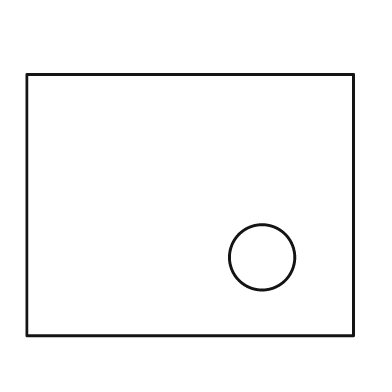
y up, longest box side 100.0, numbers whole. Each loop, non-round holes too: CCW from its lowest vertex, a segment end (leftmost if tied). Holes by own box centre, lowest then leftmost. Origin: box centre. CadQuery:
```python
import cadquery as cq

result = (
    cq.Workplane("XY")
    .moveTo(-50.0, -40.0)
    .lineTo(50.0, -40.0)
    .lineTo(50.0, 40.0)
    .lineTo(-50.0, 40.0)
    .close()
    .moveTo(22.0, -16.0)
    .circle(10.0)
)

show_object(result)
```